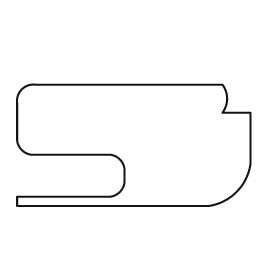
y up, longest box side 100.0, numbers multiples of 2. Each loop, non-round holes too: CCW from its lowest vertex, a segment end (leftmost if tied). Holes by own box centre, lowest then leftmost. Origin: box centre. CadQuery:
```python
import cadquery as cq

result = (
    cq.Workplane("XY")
    .moveTo(-50.0, -26.0)
    .lineTo(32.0, -26.0)
    .threePointArc((44.0, -20.0), (50.0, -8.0))
    .lineTo(50.0, 14.0)
    .lineTo(38.0, 14.0)
    .threePointArc((40.0, 20.0), (38.0, 26.0))
    .lineTo(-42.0, 26.0)
    .threePointArc((-48.0, 24.0), (-50.0, 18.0))
    .lineTo(-50.0, 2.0)
    .threePointArc((-48.0, -2.0), (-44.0, -4.0))
    .lineTo(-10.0, -4.0)
    .threePointArc((-6.0, -6.0), (-4.0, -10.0))
    .lineTo(-4.0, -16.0)
    .threePointArc((-6.0, -20.0), (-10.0, -22.0))
    .lineTo(-50.0, -22.0)
    .close()
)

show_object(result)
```